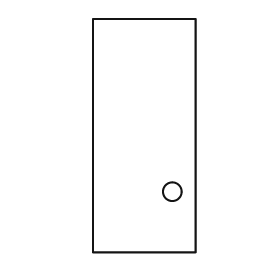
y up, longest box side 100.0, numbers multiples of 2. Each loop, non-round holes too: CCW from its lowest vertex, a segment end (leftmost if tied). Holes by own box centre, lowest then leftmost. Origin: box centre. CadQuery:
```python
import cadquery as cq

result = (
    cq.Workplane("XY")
    .moveTo(-22.0, -50.0)
    .lineTo(22.0, -50.0)
    .lineTo(22.0, 50.0)
    .lineTo(-22.0, 50.0)
    .close()
    .moveTo(12.0, -24.0)
    .circle(4.0)
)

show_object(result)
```